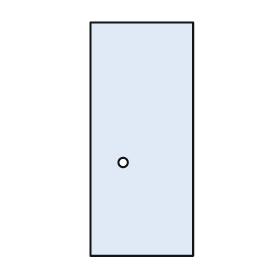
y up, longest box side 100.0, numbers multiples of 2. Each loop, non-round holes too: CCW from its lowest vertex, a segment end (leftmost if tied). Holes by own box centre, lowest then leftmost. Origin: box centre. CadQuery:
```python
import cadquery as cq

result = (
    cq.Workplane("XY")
    .moveTo(-22.0, -50.0)
    .lineTo(22.0, -50.0)
    .lineTo(22.0, 50.0)
    .lineTo(-22.0, 50.0)
    .close()
    .moveTo(-8.0, -10.0)
    .circle(2.0)
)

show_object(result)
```